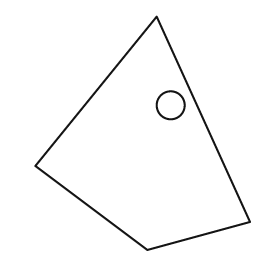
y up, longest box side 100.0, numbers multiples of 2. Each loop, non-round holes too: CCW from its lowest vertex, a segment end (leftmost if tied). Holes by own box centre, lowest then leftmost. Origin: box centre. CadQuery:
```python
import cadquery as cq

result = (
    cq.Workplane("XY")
    .moveTo(2.0, -50.0)
    .lineTo(46.0, -38.0)
    .lineTo(6.0, 50.0)
    .lineTo(-46.0, -14.0)
    .close()
    .moveTo(12.0, 12.0)
    .circle(6.0)
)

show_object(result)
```